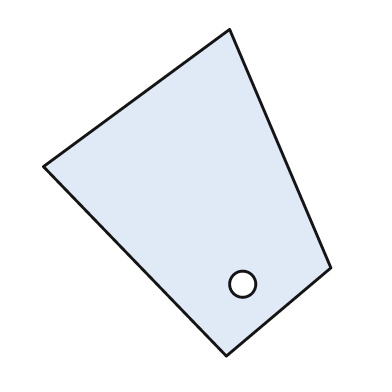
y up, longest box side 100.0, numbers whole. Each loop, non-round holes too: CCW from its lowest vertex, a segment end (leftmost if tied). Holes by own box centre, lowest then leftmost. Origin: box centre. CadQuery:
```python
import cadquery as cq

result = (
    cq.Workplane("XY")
    .moveTo(12.0, -50.0)
    .lineTo(44.0, -23.0)
    .lineTo(13.0, 50.0)
    .lineTo(-44.0, 8.0)
    .close()
    .moveTo(17.0, -28.0)
    .circle(4.0)
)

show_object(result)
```